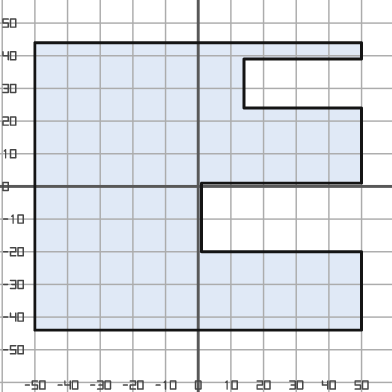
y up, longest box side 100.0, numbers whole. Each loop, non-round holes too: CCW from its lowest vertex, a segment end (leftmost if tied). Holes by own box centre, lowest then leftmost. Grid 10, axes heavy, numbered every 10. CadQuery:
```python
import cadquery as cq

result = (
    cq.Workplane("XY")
    .moveTo(-50.0, -44.0)
    .lineTo(50.0, -44.0)
    .lineTo(50.0, -20.0)
    .lineTo(1.0, -20.0)
    .lineTo(1.0, 1.0)
    .lineTo(50.0, 1.0)
    .lineTo(50.0, 24.0)
    .lineTo(14.0, 24.0)
    .lineTo(14.0, 39.0)
    .lineTo(50.0, 39.0)
    .lineTo(50.0, 44.0)
    .lineTo(-50.0, 44.0)
    .close()
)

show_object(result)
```